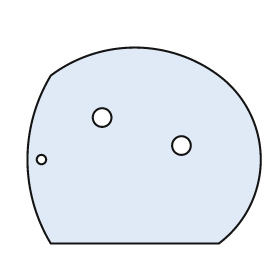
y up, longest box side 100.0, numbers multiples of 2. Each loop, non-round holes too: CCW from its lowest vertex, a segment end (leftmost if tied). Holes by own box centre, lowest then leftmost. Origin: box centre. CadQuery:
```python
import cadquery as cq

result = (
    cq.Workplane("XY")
    .moveTo(-40.0, -42.0)
    .lineTo(32.0, -42.0)
    .threePointArc((50.0, -6.0), (32.0, 30.0))
    .threePointArc((-4.0, 42.0), (-40.0, 30.0))
    .threePointArc((-50.0, -6.0), (-40.0, -42.0))
    .close()
    .moveTo(-44.0, -6.0)
    .circle(2.0)
    .moveTo(16.0, 0.0)
    .circle(4.0)
    .moveTo(-18.0, 12.0)
    .circle(4.0)
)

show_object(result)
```